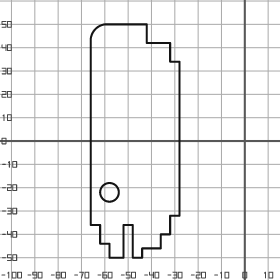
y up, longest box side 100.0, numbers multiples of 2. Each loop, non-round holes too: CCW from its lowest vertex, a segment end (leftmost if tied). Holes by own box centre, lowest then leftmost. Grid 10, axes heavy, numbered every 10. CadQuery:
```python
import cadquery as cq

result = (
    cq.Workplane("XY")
    .moveTo(-58.0, -50.0)
    .lineTo(-52.0, -50.0)
    .lineTo(-52.0, -36.0)
    .lineTo(-48.0, -36.0)
    .lineTo(-48.0, -50.0)
    .lineTo(-44.0, -50.0)
    .lineTo(-44.0, -46.0)
    .lineTo(-36.0, -46.0)
    .lineTo(-36.0, -40.0)
    .lineTo(-32.0, -40.0)
    .lineTo(-32.0, -32.0)
    .lineTo(-28.0, -32.0)
    .lineTo(-28.0, 34.0)
    .lineTo(-32.0, 34.0)
    .lineTo(-32.0, 42.0)
    .lineTo(-42.0, 42.0)
    .lineTo(-42.0, 50.0)
    .lineTo(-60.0, 50.0)
    .threePointArc((-64.0, 48.0), (-66.0, 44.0))
    .lineTo(-66.0, -36.0)
    .lineTo(-62.0, -36.0)
    .lineTo(-62.0, -44.0)
    .lineTo(-58.0, -44.0)
    .close()
    .moveTo(-58.0, -22.0)
    .circle(4.0)
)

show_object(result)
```